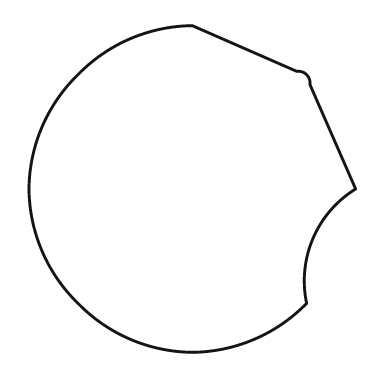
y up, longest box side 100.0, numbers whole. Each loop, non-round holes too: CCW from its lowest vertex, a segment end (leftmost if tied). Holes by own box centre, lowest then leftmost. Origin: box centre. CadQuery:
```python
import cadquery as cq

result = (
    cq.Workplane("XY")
    .moveTo(0.0, -50.0)
    .threePointArc((19.0, -46.0), (35.0, -35.0))
    .threePointArc((37.0, -15.0), (50.0, 0.0))
    .lineTo(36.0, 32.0)
    .threePointArc((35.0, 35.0), (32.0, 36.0))
    .lineTo(0.0, 50.0)
    .threePointArc((-19.0, 46.0), (-35.0, 35.0))
    .threePointArc((-46.0, 19.0), (-50.0, 0.0))
    .threePointArc((-46.0, -19.0), (-35.0, -35.0))
    .threePointArc((-19.0, -46.0), (0.0, -50.0))
    .close()
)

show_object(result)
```